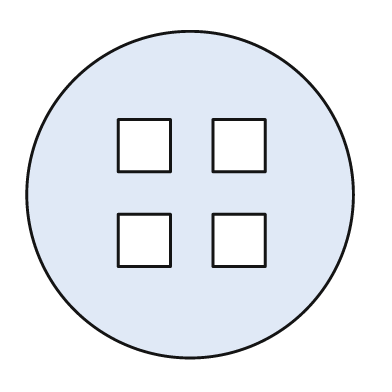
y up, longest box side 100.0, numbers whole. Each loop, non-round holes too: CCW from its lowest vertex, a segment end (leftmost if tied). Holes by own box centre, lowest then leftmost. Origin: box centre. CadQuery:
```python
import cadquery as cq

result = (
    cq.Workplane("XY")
    .moveTo(0.0, 0.0)
    .circle(50.0)
    .moveTo(-22.0, -22.0)
    .lineTo(-6.0, -22.0)
    .lineTo(-6.0, -6.0)
    .lineTo(-22.0, -6.0)
    .close()
    .moveTo(7.0, -22.0)
    .lineTo(23.0, -22.0)
    .lineTo(23.0, -6.0)
    .lineTo(7.0, -6.0)
    .close()
    .moveTo(-22.0, 7.0)
    .lineTo(-6.0, 7.0)
    .lineTo(-6.0, 23.0)
    .lineTo(-22.0, 23.0)
    .close()
    .moveTo(7.0, 7.0)
    .lineTo(23.0, 7.0)
    .lineTo(23.0, 23.0)
    .lineTo(7.0, 23.0)
    .close()
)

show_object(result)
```